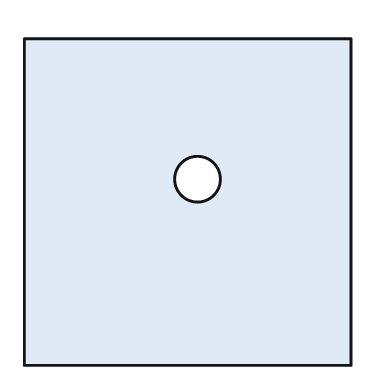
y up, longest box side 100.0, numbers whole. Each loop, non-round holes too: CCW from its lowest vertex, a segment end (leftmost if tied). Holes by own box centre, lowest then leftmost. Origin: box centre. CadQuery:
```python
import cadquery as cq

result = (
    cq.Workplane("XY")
    .moveTo(-50.0, -50.0)
    .lineTo(50.0, -50.0)
    .lineTo(50.0, 50.0)
    .lineTo(-50.0, 50.0)
    .close()
    .moveTo(3.0, 7.0)
    .circle(7.0)
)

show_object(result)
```